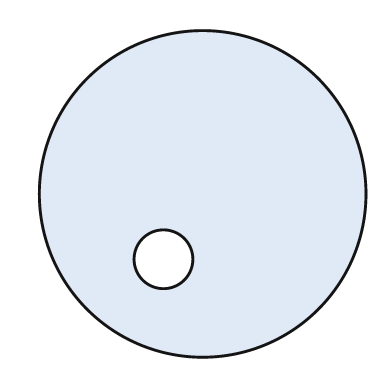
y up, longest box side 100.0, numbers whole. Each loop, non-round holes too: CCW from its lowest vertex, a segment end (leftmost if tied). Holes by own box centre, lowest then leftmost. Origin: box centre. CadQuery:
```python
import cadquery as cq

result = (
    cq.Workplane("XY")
    .moveTo(0.0, 0.0)
    .circle(50.0)
    .moveTo(-12.0, -20.0)
    .circle(9.0)
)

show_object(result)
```